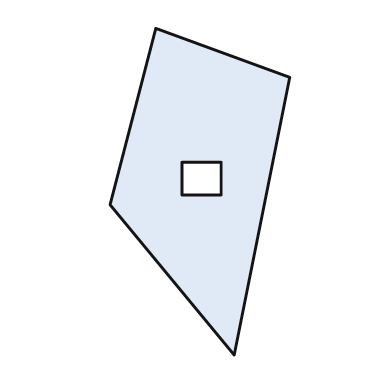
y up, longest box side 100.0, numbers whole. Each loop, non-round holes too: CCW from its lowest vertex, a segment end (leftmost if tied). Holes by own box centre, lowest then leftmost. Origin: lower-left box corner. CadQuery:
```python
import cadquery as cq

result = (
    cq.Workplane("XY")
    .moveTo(38.0, 0.0)
    .lineTo(55.0, 85.0)
    .lineTo(14.0, 100.0)
    .lineTo(0.0, 46.0)
    .close()
    .moveTo(22.0, 49.0)
    .lineTo(34.0, 49.0)
    .lineTo(34.0, 59.0)
    .lineTo(22.0, 59.0)
    .close()
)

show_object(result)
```